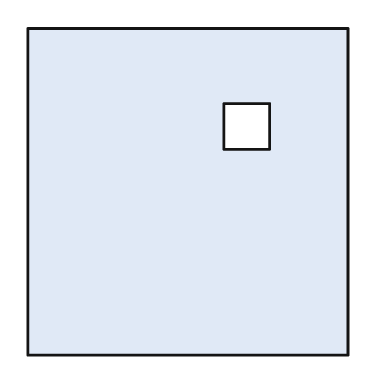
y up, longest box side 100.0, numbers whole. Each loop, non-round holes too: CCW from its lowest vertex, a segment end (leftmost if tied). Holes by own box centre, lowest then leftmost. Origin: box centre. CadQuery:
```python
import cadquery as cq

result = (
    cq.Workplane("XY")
    .moveTo(-49.0, -50.0)
    .lineTo(49.0, -50.0)
    .lineTo(49.0, 50.0)
    .lineTo(-49.0, 50.0)
    .close()
    .moveTo(11.0, 13.0)
    .lineTo(25.0, 13.0)
    .lineTo(25.0, 27.0)
    .lineTo(11.0, 27.0)
    .close()
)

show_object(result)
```